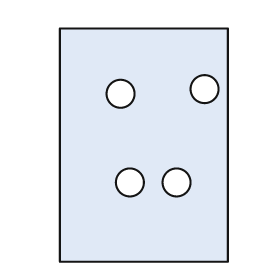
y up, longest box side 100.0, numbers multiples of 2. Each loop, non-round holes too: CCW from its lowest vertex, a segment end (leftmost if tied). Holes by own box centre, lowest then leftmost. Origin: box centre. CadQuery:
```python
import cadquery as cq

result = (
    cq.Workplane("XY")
    .moveTo(-36.0, -50.0)
    .lineTo(36.0, -50.0)
    .lineTo(36.0, 50.0)
    .lineTo(-36.0, 50.0)
    .close()
    .moveTo(-6.0, -16.0)
    .circle(6.0)
    .moveTo(14.0, -16.0)
    .circle(6.0)
    .moveTo(-10.0, 22.0)
    .circle(6.0)
    .moveTo(26.0, 24.0)
    .circle(6.0)
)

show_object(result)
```